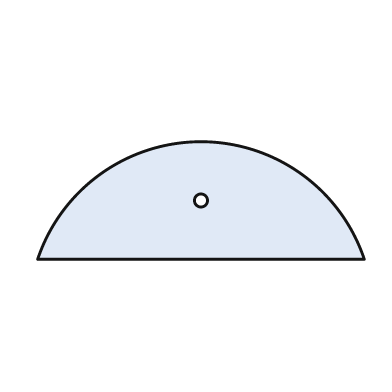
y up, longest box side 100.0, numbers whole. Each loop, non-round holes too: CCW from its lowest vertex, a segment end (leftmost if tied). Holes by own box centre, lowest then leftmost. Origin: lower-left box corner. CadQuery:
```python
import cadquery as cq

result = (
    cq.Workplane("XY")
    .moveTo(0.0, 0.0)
    .lineTo(100.0, 0.0)
    .threePointArc((50.0, 36.0), (0.0, 0.0))
    .close()
    .moveTo(50.0, 18.0)
    .circle(2.0)
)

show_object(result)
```